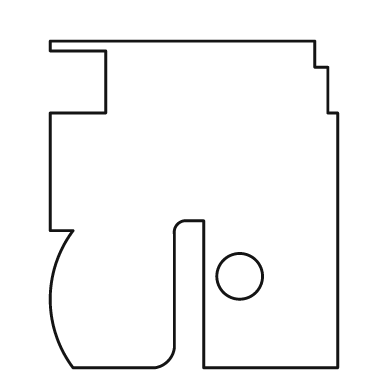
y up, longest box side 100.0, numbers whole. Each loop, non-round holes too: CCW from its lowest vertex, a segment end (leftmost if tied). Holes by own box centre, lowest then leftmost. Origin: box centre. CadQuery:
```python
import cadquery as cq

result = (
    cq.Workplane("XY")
    .moveTo(-37.0, -50.0)
    .lineTo(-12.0, -50.0)
    .threePointArc((-8.0, -48.0), (-6.0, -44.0))
    .lineTo(-6.0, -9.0)
    .threePointArc((-5.0, -6.0), (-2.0, -5.0))
    .lineTo(3.0, -5.0)
    .lineTo(3.0, -50.0)
    .lineTo(44.0, -50.0)
    .lineTo(44.0, 28.0)
    .lineTo(41.0, 28.0)
    .lineTo(41.0, 42.0)
    .lineTo(37.0, 42.0)
    .lineTo(37.0, 50.0)
    .lineTo(-44.0, 50.0)
    .lineTo(-44.0, 47.0)
    .lineTo(-27.0, 47.0)
    .lineTo(-27.0, 28.0)
    .lineTo(-44.0, 28.0)
    .lineTo(-44.0, -8.0)
    .lineTo(-37.0, -8.0)
    .threePointArc((-44.0, -29.0), (-37.0, -50.0))
    .close()
    .moveTo(14.0, -22.0)
    .circle(7.0)
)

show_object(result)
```